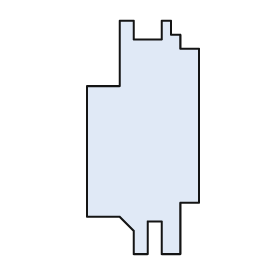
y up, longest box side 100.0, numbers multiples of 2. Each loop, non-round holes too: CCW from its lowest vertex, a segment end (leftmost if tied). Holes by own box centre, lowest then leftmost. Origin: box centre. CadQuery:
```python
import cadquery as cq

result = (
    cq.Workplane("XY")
    .moveTo(-4.0, -50.0)
    .lineTo(2.0, -50.0)
    .lineTo(2.0, -36.0)
    .lineTo(8.0, -36.0)
    .lineTo(8.0, -50.0)
    .lineTo(16.0, -50.0)
    .lineTo(16.0, -28.0)
    .lineTo(24.0, -28.0)
    .lineTo(24.0, 38.0)
    .lineTo(16.0, 38.0)
    .lineTo(16.0, 44.0)
    .lineTo(12.0, 44.0)
    .lineTo(12.0, 50.0)
    .lineTo(8.0, 50.0)
    .lineTo(8.0, 42.0)
    .lineTo(-4.0, 42.0)
    .lineTo(-4.0, 50.0)
    .lineTo(-10.0, 50.0)
    .lineTo(-10.0, 22.0)
    .lineTo(-24.0, 22.0)
    .lineTo(-24.0, -34.0)
    .lineTo(-10.0, -34.0)
    .lineTo(-4.0, -40.0)
    .close()
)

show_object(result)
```